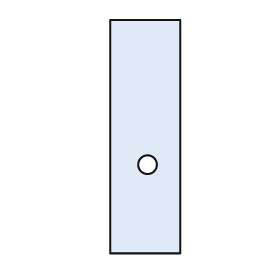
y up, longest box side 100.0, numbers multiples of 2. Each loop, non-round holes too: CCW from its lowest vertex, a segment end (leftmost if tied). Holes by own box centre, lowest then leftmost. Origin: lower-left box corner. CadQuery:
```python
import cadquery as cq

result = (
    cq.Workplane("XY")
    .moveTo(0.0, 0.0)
    .lineTo(30.0, 0.0)
    .lineTo(30.0, 100.0)
    .lineTo(0.0, 100.0)
    .close()
    .moveTo(16.0, 38.0)
    .circle(4.0)
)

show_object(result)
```